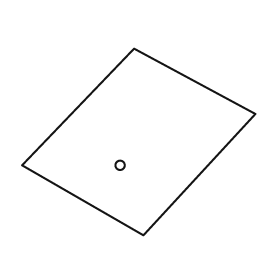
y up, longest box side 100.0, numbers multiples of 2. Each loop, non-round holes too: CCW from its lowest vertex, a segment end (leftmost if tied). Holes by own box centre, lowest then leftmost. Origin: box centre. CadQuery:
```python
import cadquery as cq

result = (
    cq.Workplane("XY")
    .moveTo(2.0, -40.0)
    .lineTo(50.0, 12.0)
    .lineTo(-2.0, 40.0)
    .lineTo(-50.0, -10.0)
    .close()
    .moveTo(-8.0, -10.0)
    .circle(2.0)
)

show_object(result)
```